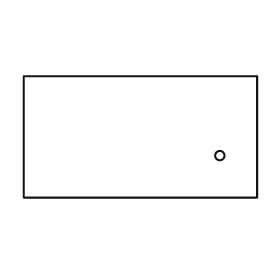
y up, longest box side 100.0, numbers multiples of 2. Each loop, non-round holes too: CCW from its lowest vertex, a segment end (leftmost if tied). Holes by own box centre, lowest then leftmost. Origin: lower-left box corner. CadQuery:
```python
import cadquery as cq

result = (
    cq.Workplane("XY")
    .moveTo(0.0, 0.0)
    .lineTo(100.0, 0.0)
    .lineTo(100.0, 52.0)
    .lineTo(0.0, 52.0)
    .close()
    .moveTo(84.0, 18.0)
    .circle(2.0)
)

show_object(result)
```